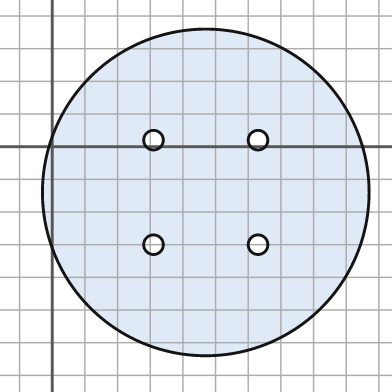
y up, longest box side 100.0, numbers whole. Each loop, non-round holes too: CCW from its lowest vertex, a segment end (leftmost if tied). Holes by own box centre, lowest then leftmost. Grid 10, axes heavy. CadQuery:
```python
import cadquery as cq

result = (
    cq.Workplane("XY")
    .moveTo(47.0, -14.0)
    .circle(50.0)
    .moveTo(31.0, -30.0)
    .circle(3.0)
    .moveTo(63.0, -30.0)
    .circle(3.0)
    .moveTo(31.0, 2.0)
    .circle(3.0)
    .moveTo(63.0, 2.0)
    .circle(3.0)
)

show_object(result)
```